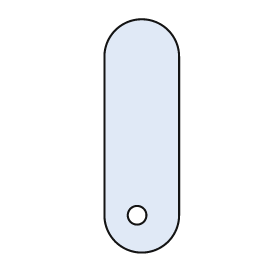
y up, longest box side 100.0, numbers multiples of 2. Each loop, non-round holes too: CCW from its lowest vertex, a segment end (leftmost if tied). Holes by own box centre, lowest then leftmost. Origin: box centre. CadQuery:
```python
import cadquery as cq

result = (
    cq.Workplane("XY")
    .moveTo(-16.0, -34.0)
    .threePointArc((0.0, -50.0), (16.0, -34.0))
    .lineTo(16.0, 34.0)
    .threePointArc((0.0, 50.0), (-16.0, 34.0))
    .close()
    .moveTo(-2.0, -34.0)
    .circle(4.0)
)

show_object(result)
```